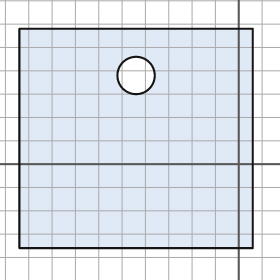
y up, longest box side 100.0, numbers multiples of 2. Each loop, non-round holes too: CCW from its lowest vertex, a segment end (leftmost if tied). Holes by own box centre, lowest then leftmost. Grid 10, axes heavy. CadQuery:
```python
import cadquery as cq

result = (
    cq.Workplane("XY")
    .moveTo(-94.0, -36.0)
    .lineTo(6.0, -36.0)
    .lineTo(6.0, 58.0)
    .lineTo(-94.0, 58.0)
    .close()
    .moveTo(-44.0, 38.0)
    .circle(8.0)
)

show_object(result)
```